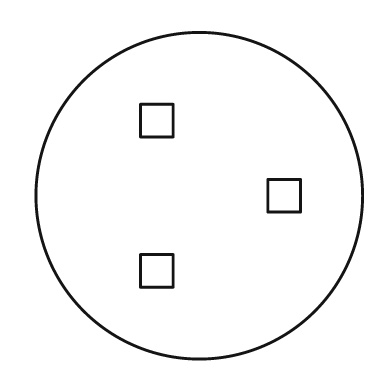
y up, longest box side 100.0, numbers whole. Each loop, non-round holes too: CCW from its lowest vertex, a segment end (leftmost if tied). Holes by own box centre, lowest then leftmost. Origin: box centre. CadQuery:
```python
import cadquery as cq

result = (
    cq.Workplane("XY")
    .moveTo(0.0, 0.0)
    .circle(50.0)
    .moveTo(-18.0, -28.0)
    .lineTo(-8.0, -28.0)
    .lineTo(-8.0, -18.0)
    .lineTo(-18.0, -18.0)
    .close()
    .moveTo(21.0, -5.0)
    .lineTo(31.0, -5.0)
    .lineTo(31.0, 5.0)
    .lineTo(21.0, 5.0)
    .close()
    .moveTo(-18.0, 18.0)
    .lineTo(-8.0, 18.0)
    .lineTo(-8.0, 28.0)
    .lineTo(-18.0, 28.0)
    .close()
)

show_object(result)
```